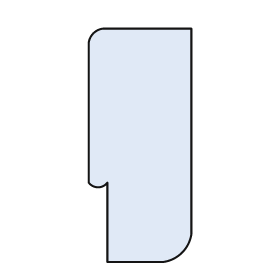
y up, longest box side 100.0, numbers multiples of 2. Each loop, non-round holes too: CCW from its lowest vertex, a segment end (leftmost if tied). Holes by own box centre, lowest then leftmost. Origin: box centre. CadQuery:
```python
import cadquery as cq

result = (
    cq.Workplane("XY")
    .moveTo(-14.0, -50.0)
    .lineTo(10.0, -50.0)
    .threePointArc((18.0, -46.0), (22.0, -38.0))
    .lineTo(22.0, 50.0)
    .lineTo(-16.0, 50.0)
    .threePointArc((-20.0, 48.0), (-22.0, 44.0))
    .lineTo(-22.0, -16.0)
    .threePointArc((-18.0, -18.0), (-14.0, -16.0))
    .close()
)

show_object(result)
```